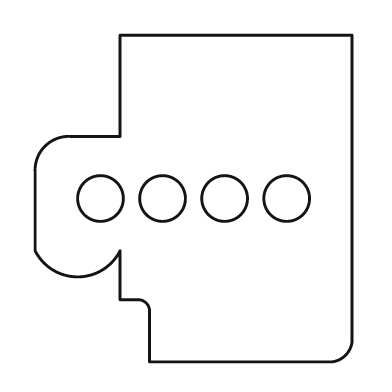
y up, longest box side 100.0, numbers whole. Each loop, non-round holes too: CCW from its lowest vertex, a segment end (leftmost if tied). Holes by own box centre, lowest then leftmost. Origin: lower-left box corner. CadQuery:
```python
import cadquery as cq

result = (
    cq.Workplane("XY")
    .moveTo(35.0, 0.0)
    .lineTo(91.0, 0.0)
    .threePointArc((95.0, 2.0), (97.0, 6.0))
    .lineTo(97.0, 100.0)
    .lineTo(26.0, 100.0)
    .lineTo(26.0, 69.0)
    .lineTo(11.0, 69.0)
    .threePointArc((3.0, 66.0), (0.0, 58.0))
    .lineTo(0.0, 34.0)
    .threePointArc((13.0, 26.0), (26.0, 34.0))
    .lineTo(26.0, 19.0)
    .lineTo(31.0, 19.0)
    .threePointArc((34.0, 18.0), (35.0, 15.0))
    .close()
    .moveTo(20.0, 50.0)
    .circle(7.0)
    .moveTo(39.0, 50.0)
    .circle(7.0)
    .moveTo(58.0, 50.0)
    .circle(7.0)
    .moveTo(77.0, 50.0)
    .circle(7.0)
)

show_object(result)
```